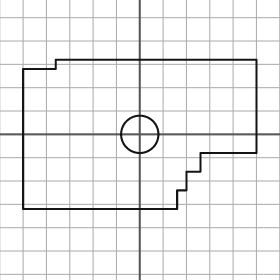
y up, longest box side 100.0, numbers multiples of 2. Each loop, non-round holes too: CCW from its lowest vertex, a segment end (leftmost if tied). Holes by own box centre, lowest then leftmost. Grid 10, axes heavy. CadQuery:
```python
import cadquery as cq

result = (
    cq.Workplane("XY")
    .moveTo(-50.0, -32.0)
    .lineTo(16.0, -32.0)
    .lineTo(16.0, -24.0)
    .lineTo(20.0, -24.0)
    .lineTo(20.0, -16.0)
    .lineTo(26.0, -16.0)
    .lineTo(26.0, -8.0)
    .lineTo(50.0, -8.0)
    .lineTo(50.0, 32.0)
    .lineTo(-36.0, 32.0)
    .lineTo(-36.0, 28.0)
    .lineTo(-50.0, 28.0)
    .close()
    .moveTo(0.0, 0.0)
    .circle(8.0)
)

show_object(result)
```